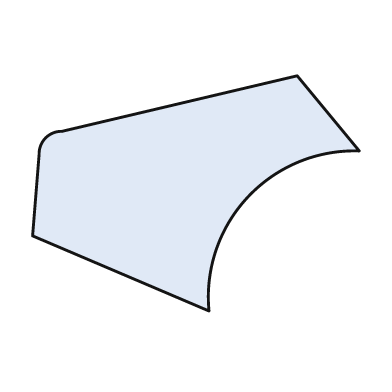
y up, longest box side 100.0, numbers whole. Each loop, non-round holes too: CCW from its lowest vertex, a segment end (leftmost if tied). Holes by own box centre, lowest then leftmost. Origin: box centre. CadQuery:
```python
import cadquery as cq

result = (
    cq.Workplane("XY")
    .moveTo(4.0, -36.0)
    .threePointArc((16.0, -1.0), (50.0, 13.0))
    .lineTo(31.0, 36.0)
    .lineTo(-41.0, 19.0)
    .threePointArc((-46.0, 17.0), (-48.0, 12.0))
    .lineTo(-50.0, -13.0)
    .close()
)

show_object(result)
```